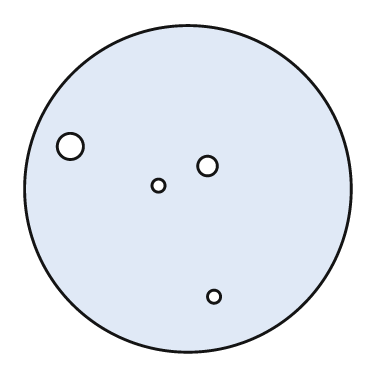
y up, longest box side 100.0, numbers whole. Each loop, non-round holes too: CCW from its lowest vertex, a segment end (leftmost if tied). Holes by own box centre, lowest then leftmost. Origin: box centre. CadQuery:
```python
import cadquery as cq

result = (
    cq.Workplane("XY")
    .moveTo(0.0, 0.0)
    .circle(50.0)
    .moveTo(8.0, -33.0)
    .circle(2.0)
    .moveTo(-9.0, 1.0)
    .circle(2.0)
    .moveTo(6.0, 7.0)
    .circle(3.0)
    .moveTo(-36.0, 13.0)
    .circle(4.0)
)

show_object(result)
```